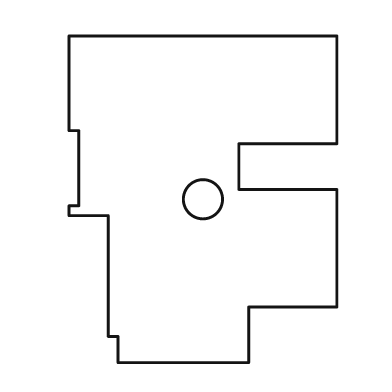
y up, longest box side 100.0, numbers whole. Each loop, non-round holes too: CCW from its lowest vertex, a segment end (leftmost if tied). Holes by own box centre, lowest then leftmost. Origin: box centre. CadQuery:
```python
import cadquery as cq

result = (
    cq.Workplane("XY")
    .moveTo(-26.0, -50.0)
    .lineTo(14.0, -50.0)
    .lineTo(14.0, -33.0)
    .lineTo(41.0, -33.0)
    .lineTo(41.0, 3.0)
    .lineTo(11.0, 3.0)
    .lineTo(11.0, 17.0)
    .lineTo(41.0, 17.0)
    .lineTo(41.0, 50.0)
    .lineTo(-41.0, 50.0)
    .lineTo(-41.0, 21.0)
    .lineTo(-38.0, 21.0)
    .lineTo(-38.0, -2.0)
    .lineTo(-41.0, -2.0)
    .lineTo(-41.0, -5.0)
    .lineTo(-29.0, -5.0)
    .lineTo(-29.0, -42.0)
    .lineTo(-26.0, -42.0)
    .close()
    .moveTo(0.0, 0.0)
    .circle(6.0)
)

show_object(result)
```